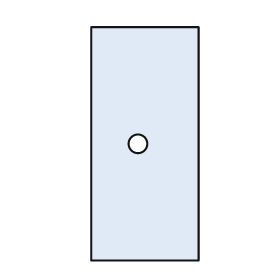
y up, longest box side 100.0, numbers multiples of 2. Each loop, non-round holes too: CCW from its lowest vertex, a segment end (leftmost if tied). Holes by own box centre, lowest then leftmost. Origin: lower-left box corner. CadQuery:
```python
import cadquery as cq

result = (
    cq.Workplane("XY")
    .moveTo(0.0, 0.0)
    .lineTo(46.0, 0.0)
    .lineTo(46.0, 100.0)
    .lineTo(0.0, 100.0)
    .close()
    .moveTo(20.0, 50.0)
    .circle(4.0)
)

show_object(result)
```